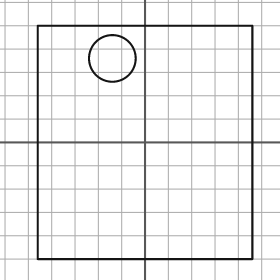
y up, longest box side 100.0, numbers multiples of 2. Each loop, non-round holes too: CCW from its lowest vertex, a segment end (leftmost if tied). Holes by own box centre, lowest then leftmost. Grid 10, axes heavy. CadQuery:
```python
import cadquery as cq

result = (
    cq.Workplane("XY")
    .moveTo(-46.0, -50.0)
    .lineTo(46.0, -50.0)
    .lineTo(46.0, 50.0)
    .lineTo(-46.0, 50.0)
    .close()
    .moveTo(-14.0, 36.0)
    .circle(10.0)
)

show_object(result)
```